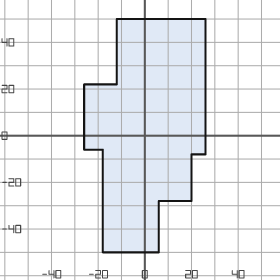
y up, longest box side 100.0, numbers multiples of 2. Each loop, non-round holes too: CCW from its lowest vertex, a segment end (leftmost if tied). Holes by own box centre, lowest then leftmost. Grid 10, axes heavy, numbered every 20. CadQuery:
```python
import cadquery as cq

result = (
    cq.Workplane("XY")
    .moveTo(-18.0, -50.0)
    .lineTo(6.0, -50.0)
    .lineTo(6.0, -28.0)
    .lineTo(20.0, -28.0)
    .lineTo(20.0, -8.0)
    .lineTo(26.0, -8.0)
    .lineTo(26.0, 50.0)
    .lineTo(-12.0, 50.0)
    .lineTo(-12.0, 22.0)
    .lineTo(-26.0, 22.0)
    .lineTo(-26.0, -6.0)
    .lineTo(-18.0, -6.0)
    .close()
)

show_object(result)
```